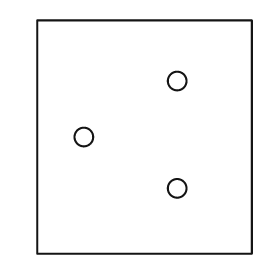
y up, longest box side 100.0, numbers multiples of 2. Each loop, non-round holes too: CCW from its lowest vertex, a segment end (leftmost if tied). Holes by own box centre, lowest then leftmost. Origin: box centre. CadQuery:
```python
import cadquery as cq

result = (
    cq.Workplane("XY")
    .moveTo(-46.0, -50.0)
    .lineTo(46.0, -50.0)
    .lineTo(46.0, 50.0)
    .lineTo(-46.0, 50.0)
    .close()
    .moveTo(14.0, -22.0)
    .circle(4.0)
    .moveTo(-26.0, 0.0)
    .circle(4.0)
    .moveTo(14.0, 24.0)
    .circle(4.0)
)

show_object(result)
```